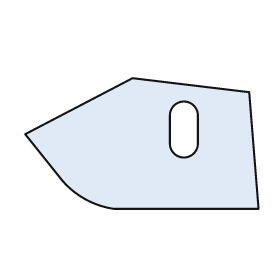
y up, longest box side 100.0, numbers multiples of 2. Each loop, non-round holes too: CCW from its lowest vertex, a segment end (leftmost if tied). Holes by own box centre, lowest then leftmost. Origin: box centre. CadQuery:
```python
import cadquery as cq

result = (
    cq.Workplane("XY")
    .moveTo(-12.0, -28.0)
    .lineTo(50.0, -28.0)
    .lineTo(46.0, 22.0)
    .lineTo(-4.0, 28.0)
    .lineTo(-50.0, 4.0)
    .lineTo(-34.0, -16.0)
    .threePointArc((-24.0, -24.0), (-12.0, -28.0))
    .close()
    .moveTo(12.0, 0.0)
    .threePointArc((18.0, -6.0), (24.0, 0.0))
    .lineTo(24.0, 12.0)
    .threePointArc((18.0, 18.0), (12.0, 12.0))
    .close()
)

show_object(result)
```